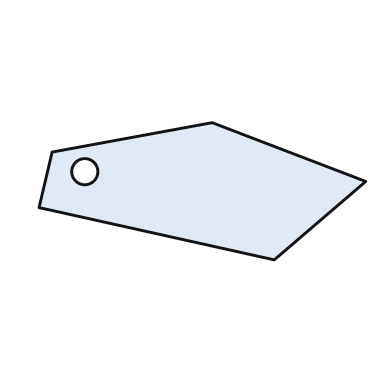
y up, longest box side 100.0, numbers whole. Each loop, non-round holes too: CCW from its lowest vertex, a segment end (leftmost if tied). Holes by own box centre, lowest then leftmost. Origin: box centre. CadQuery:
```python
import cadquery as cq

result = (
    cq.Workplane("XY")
    .moveTo(22.0, -21.0)
    .lineTo(50.0, 3.0)
    .lineTo(3.0, 21.0)
    .lineTo(-46.0, 12.0)
    .lineTo(-50.0, -5.0)
    .close()
    .moveTo(-36.0, 6.0)
    .circle(4.0)
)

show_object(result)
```